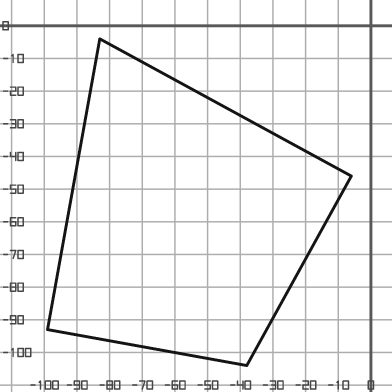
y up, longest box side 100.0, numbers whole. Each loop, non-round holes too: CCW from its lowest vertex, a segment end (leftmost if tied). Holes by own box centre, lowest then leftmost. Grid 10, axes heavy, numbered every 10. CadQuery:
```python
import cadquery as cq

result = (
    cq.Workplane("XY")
    .moveTo(-38.0, -104.0)
    .lineTo(-6.0, -46.0)
    .lineTo(-83.0, -4.0)
    .lineTo(-99.0, -93.0)
    .close()
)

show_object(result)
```